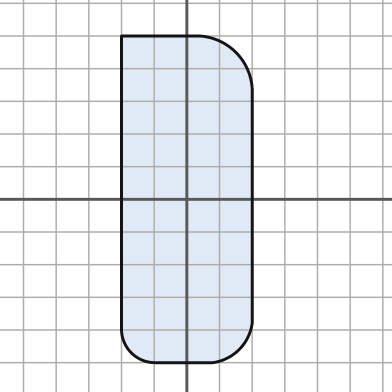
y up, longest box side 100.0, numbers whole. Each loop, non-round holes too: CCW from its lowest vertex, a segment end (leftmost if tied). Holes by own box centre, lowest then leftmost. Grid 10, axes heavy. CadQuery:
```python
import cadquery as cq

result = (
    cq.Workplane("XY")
    .moveTo(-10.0, -50.0)
    .lineTo(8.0, -50.0)
    .threePointArc((16.0, -46.0), (20.0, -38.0))
    .lineTo(20.0, 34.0)
    .threePointArc((15.0, 45.0), (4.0, 50.0))
    .lineTo(-20.0, 50.0)
    .lineTo(-20.0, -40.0)
    .threePointArc((-17.0, -47.0), (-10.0, -50.0))
    .close()
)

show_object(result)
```